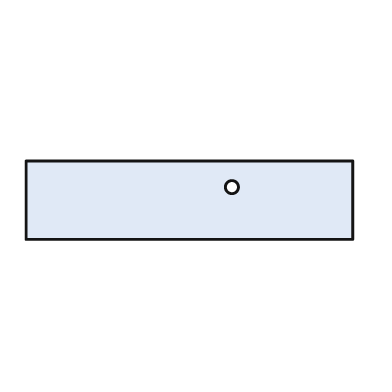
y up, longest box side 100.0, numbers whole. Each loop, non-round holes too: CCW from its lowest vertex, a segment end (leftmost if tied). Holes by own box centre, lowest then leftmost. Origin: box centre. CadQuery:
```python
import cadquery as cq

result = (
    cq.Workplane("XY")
    .moveTo(-50.0, -12.0)
    .lineTo(50.0, -12.0)
    .lineTo(50.0, 12.0)
    .lineTo(-50.0, 12.0)
    .close()
    .moveTo(13.0, 4.0)
    .circle(2.0)
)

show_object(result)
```